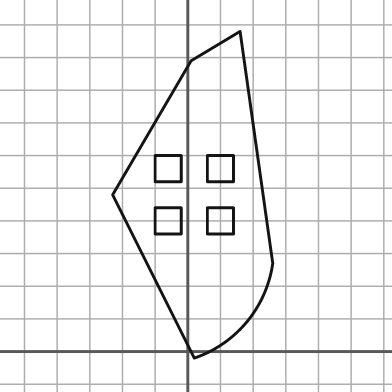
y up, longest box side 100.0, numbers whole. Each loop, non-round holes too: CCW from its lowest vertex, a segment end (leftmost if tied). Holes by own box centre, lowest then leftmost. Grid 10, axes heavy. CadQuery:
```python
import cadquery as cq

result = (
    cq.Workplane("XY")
    .moveTo(2.0, -2.0)
    .threePointArc((18.0, 9.0), (26.0, 27.0))
    .lineTo(16.0, 98.0)
    .lineTo(1.0, 89.0)
    .lineTo(-23.0, 48.0)
    .close()
    .moveTo(-10.0, 36.0)
    .lineTo(-2.0, 36.0)
    .lineTo(-2.0, 44.0)
    .lineTo(-10.0, 44.0)
    .close()
    .moveTo(6.0, 36.0)
    .lineTo(14.0, 36.0)
    .lineTo(14.0, 44.0)
    .lineTo(6.0, 44.0)
    .close()
    .moveTo(-10.0, 52.0)
    .lineTo(-2.0, 52.0)
    .lineTo(-2.0, 60.0)
    .lineTo(-10.0, 60.0)
    .close()
    .moveTo(6.0, 52.0)
    .lineTo(14.0, 52.0)
    .lineTo(14.0, 60.0)
    .lineTo(6.0, 60.0)
    .close()
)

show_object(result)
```